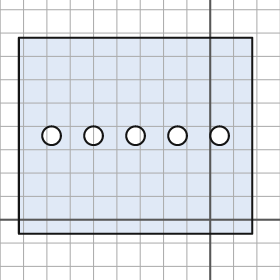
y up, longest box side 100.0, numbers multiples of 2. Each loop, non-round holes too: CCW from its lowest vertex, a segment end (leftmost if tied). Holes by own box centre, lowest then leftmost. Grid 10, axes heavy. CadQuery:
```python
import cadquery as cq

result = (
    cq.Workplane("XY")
    .moveTo(-82.0, -6.0)
    .lineTo(18.0, -6.0)
    .lineTo(18.0, 78.0)
    .lineTo(-82.0, 78.0)
    .close()
    .moveTo(-68.0, 36.0)
    .circle(4.0)
    .moveTo(-50.0, 36.0)
    .circle(4.0)
    .moveTo(-32.0, 36.0)
    .circle(4.0)
    .moveTo(-14.0, 36.0)
    .circle(4.0)
    .moveTo(4.0, 36.0)
    .circle(4.0)
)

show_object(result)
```